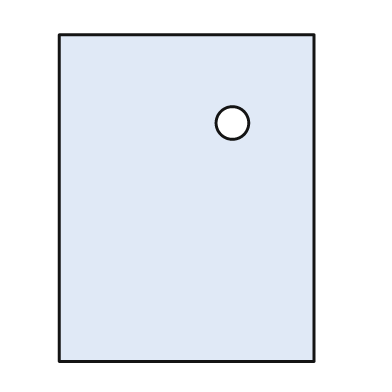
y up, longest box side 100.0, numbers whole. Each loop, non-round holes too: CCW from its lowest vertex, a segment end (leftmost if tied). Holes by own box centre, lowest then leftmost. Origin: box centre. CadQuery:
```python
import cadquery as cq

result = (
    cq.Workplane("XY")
    .moveTo(-39.0, -50.0)
    .lineTo(39.0, -50.0)
    .lineTo(39.0, 50.0)
    .lineTo(-39.0, 50.0)
    .close()
    .moveTo(14.0, 23.0)
    .circle(5.0)
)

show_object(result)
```